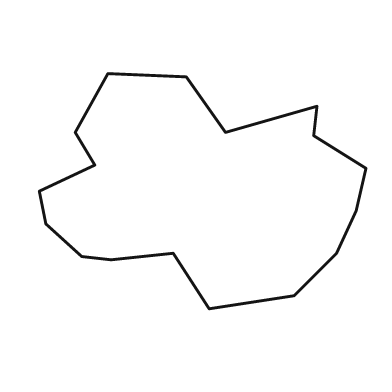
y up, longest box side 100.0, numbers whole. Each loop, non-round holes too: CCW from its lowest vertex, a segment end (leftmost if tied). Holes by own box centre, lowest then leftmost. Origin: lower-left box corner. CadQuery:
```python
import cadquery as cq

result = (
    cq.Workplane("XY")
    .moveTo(52.0, 0.0)
    .lineTo(78.0, 4.0)
    .lineTo(91.0, 17.0)
    .lineTo(97.0, 30.0)
    .lineTo(100.0, 43.0)
    .lineTo(84.0, 53.0)
    .lineTo(85.0, 62.0)
    .lineTo(57.0, 54.0)
    .lineTo(45.0, 71.0)
    .lineTo(21.0, 72.0)
    .lineTo(11.0, 54.0)
    .lineTo(17.0, 44.0)
    .lineTo(0.0, 36.0)
    .lineTo(2.0, 26.0)
    .lineTo(13.0, 16.0)
    .lineTo(22.0, 15.0)
    .lineTo(41.0, 17.0)
    .close()
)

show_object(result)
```